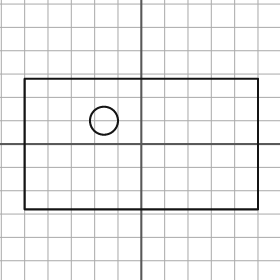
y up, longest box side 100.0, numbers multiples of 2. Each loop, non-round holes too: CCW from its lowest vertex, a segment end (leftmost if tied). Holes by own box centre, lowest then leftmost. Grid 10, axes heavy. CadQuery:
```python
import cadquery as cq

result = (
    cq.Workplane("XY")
    .moveTo(-50.0, -28.0)
    .lineTo(50.0, -28.0)
    .lineTo(50.0, 28.0)
    .lineTo(-50.0, 28.0)
    .close()
    .moveTo(-16.0, 10.0)
    .circle(6.0)
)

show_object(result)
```